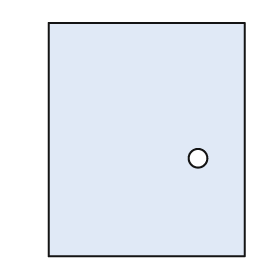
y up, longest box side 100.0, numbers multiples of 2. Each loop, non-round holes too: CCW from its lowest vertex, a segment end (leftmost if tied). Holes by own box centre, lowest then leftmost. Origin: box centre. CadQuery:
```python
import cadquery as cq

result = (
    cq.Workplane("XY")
    .moveTo(-42.0, -50.0)
    .lineTo(42.0, -50.0)
    .lineTo(42.0, 50.0)
    .lineTo(-42.0, 50.0)
    .close()
    .moveTo(22.0, -8.0)
    .circle(4.0)
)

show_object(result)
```